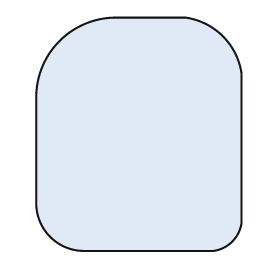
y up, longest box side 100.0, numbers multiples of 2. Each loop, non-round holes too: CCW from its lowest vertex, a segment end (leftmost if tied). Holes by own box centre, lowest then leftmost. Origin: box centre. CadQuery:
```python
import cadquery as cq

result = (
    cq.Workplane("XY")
    .moveTo(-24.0, -50.0)
    .lineTo(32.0, -50.0)
    .threePointArc((40.0, -46.0), (44.0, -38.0))
    .lineTo(44.0, 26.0)
    .threePointArc((36.0, 42.0), (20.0, 50.0))
    .lineTo(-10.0, 50.0)
    .threePointArc((-34.0, 40.0), (-44.0, 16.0))
    .lineTo(-44.0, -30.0)
    .threePointArc((-38.0, -44.0), (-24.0, -50.0))
    .close()
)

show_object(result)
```